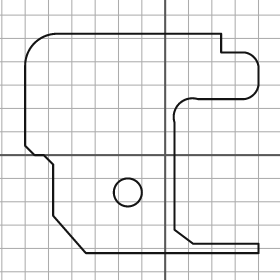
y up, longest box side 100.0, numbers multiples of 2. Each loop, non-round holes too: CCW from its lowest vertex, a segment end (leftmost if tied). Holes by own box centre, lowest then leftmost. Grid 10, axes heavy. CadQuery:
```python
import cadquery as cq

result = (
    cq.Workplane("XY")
    .moveTo(-34.0, -42.0)
    .lineTo(40.0, -42.0)
    .lineTo(40.0, -38.0)
    .lineTo(12.0, -38.0)
    .lineTo(4.0, -32.0)
    .lineTo(4.0, 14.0)
    .threePointArc((6.0, 22.0), (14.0, 24.0))
    .lineTo(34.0, 24.0)
    .threePointArc((38.0, 26.0), (40.0, 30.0))
    .lineTo(40.0, 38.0)
    .threePointArc((38.0, 42.0), (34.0, 44.0))
    .lineTo(24.0, 44.0)
    .lineTo(24.0, 52.0)
    .lineTo(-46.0, 52.0)
    .threePointArc((-56.0, 48.0), (-60.0, 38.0))
    .lineTo(-60.0, 4.0)
    .lineTo(-56.0, 0.0)
    .lineTo(-52.0, 0.0)
    .lineTo(-48.0, -4.0)
    .lineTo(-48.0, -26.0)
    .close()
    .moveTo(-16.0, -16.0)
    .circle(6.0)
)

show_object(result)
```